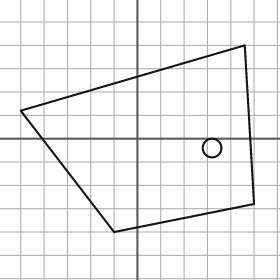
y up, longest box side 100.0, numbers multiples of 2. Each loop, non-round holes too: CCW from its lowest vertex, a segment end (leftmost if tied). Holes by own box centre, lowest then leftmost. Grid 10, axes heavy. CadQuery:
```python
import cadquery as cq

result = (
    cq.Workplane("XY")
    .moveTo(-10.0, -40.0)
    .lineTo(50.0, -28.0)
    .lineTo(46.0, 40.0)
    .lineTo(-50.0, 12.0)
    .close()
    .moveTo(32.0, -4.0)
    .circle(4.0)
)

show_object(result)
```